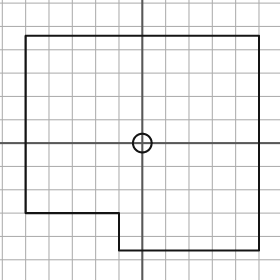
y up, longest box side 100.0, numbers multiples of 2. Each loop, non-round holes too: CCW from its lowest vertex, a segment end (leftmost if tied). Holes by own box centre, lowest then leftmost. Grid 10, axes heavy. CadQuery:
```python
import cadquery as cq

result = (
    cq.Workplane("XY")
    .moveTo(-10.0, -46.0)
    .lineTo(50.0, -46.0)
    .lineTo(50.0, 46.0)
    .lineTo(-50.0, 46.0)
    .lineTo(-50.0, -30.0)
    .lineTo(-10.0, -30.0)
    .close()
    .moveTo(0.0, 0.0)
    .circle(4.0)
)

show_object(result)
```